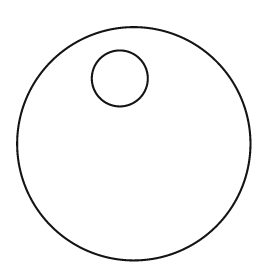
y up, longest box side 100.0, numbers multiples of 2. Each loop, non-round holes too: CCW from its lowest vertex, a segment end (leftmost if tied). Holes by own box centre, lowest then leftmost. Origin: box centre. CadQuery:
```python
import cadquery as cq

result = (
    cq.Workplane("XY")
    .moveTo(0.0, 0.0)
    .circle(50.0)
    .moveTo(-6.0, 28.0)
    .circle(12.0)
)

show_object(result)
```